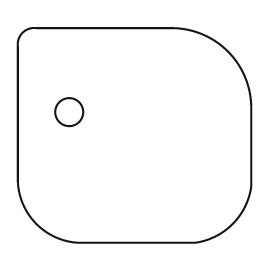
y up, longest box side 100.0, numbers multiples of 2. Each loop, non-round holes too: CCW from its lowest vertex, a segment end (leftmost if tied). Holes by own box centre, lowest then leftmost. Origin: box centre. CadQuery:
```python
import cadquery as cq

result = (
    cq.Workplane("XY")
    .moveTo(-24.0, -46.0)
    .lineTo(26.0, -46.0)
    .threePointArc((42.0, -38.0), (50.0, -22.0))
    .lineTo(50.0, 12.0)
    .threePointArc((40.0, 36.0), (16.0, 46.0))
    .lineTo(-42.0, 46.0)
    .threePointArc((-48.0, 44.0), (-50.0, 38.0))
    .lineTo(-50.0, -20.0)
    .threePointArc((-42.0, -38.0), (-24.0, -46.0))
    .close()
    .moveTo(-28.0, 10.0)
    .circle(6.0)
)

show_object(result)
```